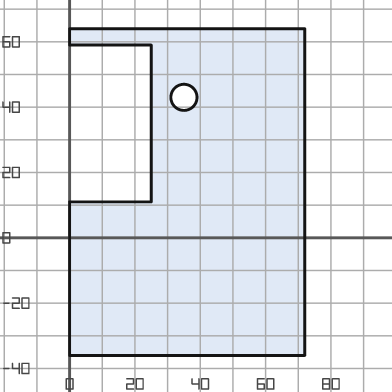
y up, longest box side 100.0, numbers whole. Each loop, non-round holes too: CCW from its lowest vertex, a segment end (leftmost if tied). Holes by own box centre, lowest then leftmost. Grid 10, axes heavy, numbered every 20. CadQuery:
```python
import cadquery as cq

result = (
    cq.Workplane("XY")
    .moveTo(0.0, -36.0)
    .lineTo(72.0, -36.0)
    .lineTo(72.0, 64.0)
    .lineTo(0.0, 64.0)
    .lineTo(0.0, 59.0)
    .lineTo(25.0, 59.0)
    .lineTo(25.0, 11.0)
    .lineTo(0.0, 11.0)
    .close()
    .moveTo(35.0, 43.0)
    .circle(4.0)
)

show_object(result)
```